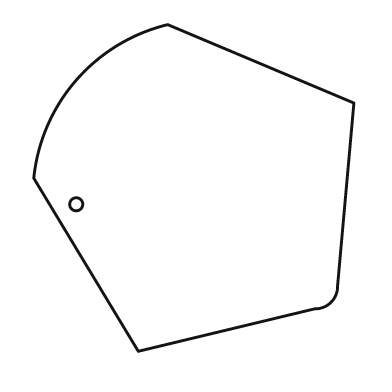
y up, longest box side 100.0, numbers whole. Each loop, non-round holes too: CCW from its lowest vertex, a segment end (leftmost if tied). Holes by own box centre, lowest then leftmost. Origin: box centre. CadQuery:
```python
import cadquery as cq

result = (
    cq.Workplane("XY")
    .moveTo(-17.0, -50.0)
    .lineTo(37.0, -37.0)
    .threePointArc((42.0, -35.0), (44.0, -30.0))
    .lineTo(49.0, 26.0)
    .lineTo(-8.0, 50.0)
    .threePointArc((-36.0, 33.0), (-49.0, 3.0))
    .close()
    .moveTo(-36.0, -5.0)
    .circle(2.0)
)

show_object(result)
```